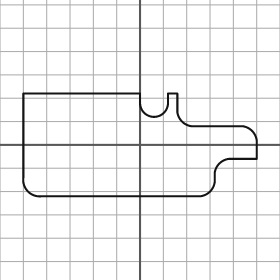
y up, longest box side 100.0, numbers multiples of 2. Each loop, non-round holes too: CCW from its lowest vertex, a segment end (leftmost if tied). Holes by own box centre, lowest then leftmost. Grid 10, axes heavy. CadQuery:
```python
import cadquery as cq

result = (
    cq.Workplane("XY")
    .moveTo(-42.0, -22.0)
    .lineTo(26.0, -22.0)
    .threePointArc((30.0, -20.0), (32.0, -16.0))
    .lineTo(32.0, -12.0)
    .threePointArc((34.0, -8.0), (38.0, -6.0))
    .lineTo(50.0, -6.0)
    .lineTo(50.0, 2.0)
    .threePointArc((48.0, 6.0), (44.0, 8.0))
    .lineTo(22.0, 8.0)
    .threePointArc((18.0, 10.0), (16.0, 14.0))
    .lineTo(16.0, 22.0)
    .lineTo(12.0, 22.0)
    .lineTo(12.0, 18.0)
    .threePointArc((6.0, 12.0), (0.0, 18.0))
    .lineTo(0.0, 22.0)
    .lineTo(-50.0, 22.0)
    .lineTo(-50.0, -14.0)
    .threePointArc((-48.0, -20.0), (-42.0, -22.0))
    .close()
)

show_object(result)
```